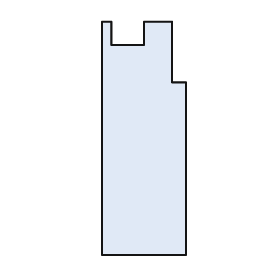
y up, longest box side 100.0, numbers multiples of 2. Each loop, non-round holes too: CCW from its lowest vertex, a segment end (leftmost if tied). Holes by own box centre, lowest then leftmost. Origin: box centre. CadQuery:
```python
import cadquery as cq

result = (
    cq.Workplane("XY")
    .moveTo(-18.0, -50.0)
    .lineTo(18.0, -50.0)
    .lineTo(18.0, 24.0)
    .lineTo(12.0, 24.0)
    .lineTo(12.0, 50.0)
    .lineTo(0.0, 50.0)
    .lineTo(0.0, 40.0)
    .lineTo(-14.0, 40.0)
    .lineTo(-14.0, 50.0)
    .lineTo(-18.0, 50.0)
    .close()
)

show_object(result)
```